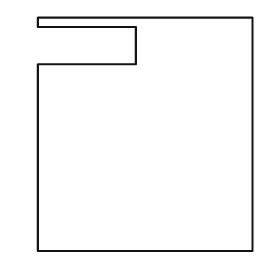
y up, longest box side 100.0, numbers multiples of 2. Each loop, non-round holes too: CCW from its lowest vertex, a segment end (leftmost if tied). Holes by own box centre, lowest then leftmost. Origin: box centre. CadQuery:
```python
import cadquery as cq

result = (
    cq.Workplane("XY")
    .moveTo(-46.0, -50.0)
    .lineTo(46.0, -50.0)
    .lineTo(46.0, 50.0)
    .lineTo(-46.0, 50.0)
    .lineTo(-46.0, 46.0)
    .lineTo(-4.0, 46.0)
    .lineTo(-4.0, 30.0)
    .lineTo(-46.0, 30.0)
    .close()
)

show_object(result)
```